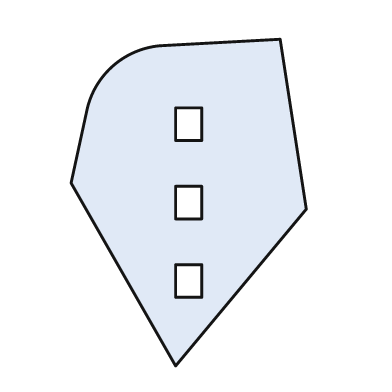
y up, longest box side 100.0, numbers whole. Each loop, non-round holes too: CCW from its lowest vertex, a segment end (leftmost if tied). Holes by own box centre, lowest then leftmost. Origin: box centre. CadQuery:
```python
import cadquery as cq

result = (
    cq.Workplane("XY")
    .moveTo(-4.0, -50.0)
    .lineTo(36.0, -2.0)
    .lineTo(28.0, 50.0)
    .lineTo(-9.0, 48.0)
    .threePointArc((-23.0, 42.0), (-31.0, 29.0))
    .lineTo(-36.0, 6.0)
    .close()
    .moveTo(-4.0, -29.0)
    .lineTo(4.0, -29.0)
    .lineTo(4.0, -19.0)
    .lineTo(-4.0, -19.0)
    .close()
    .moveTo(-4.0, -5.0)
    .lineTo(4.0, -5.0)
    .lineTo(4.0, 5.0)
    .lineTo(-4.0, 5.0)
    .close()
    .moveTo(-4.0, 19.0)
    .lineTo(4.0, 19.0)
    .lineTo(4.0, 29.0)
    .lineTo(-4.0, 29.0)
    .close()
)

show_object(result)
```